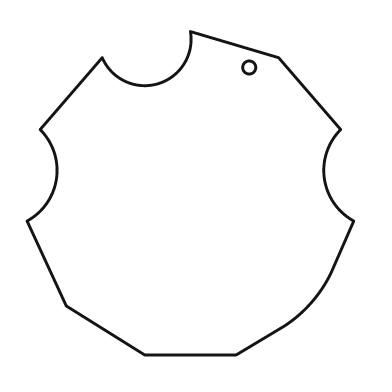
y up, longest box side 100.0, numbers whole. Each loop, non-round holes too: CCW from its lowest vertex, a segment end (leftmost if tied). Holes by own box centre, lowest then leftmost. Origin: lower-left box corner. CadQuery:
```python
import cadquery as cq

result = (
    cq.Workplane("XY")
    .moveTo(36.0, 0.0)
    .lineTo(64.0, 0.0)
    .lineTo(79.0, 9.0)
    .threePointArc((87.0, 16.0), (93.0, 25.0))
    .lineTo(100.0, 41.0)
    .threePointArc((91.0, 54.0), (96.0, 69.0))
    .lineTo(77.0, 91.0)
    .lineTo(50.0, 99.0)
    .threePointArc((40.0, 83.0), (23.0, 91.0))
    .lineTo(4.0, 69.0)
    .threePointArc((9.0, 54.0), (0.0, 41.0))
    .lineTo(12.0, 15.0)
    .close()
    .moveTo(68.0, 88.0)
    .circle(2.0)
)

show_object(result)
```